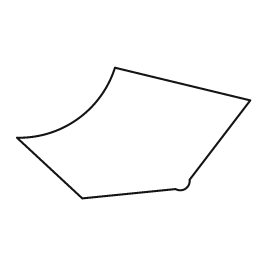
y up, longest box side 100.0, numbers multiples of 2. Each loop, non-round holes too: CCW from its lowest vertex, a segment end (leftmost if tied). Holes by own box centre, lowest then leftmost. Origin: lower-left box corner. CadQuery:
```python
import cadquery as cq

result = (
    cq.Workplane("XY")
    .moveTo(28.0, 0.0)
    .lineTo(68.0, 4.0)
    .threePointArc((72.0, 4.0), (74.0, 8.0))
    .lineTo(100.0, 42.0)
    .lineTo(42.0, 56.0)
    .threePointArc((26.0, 34.0), (0.0, 26.0))
    .close()
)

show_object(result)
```